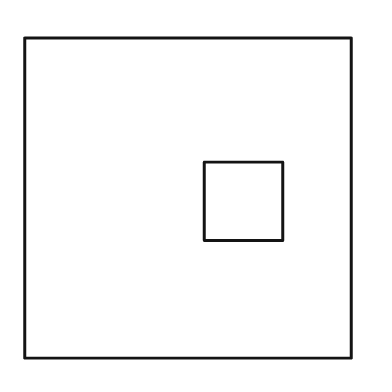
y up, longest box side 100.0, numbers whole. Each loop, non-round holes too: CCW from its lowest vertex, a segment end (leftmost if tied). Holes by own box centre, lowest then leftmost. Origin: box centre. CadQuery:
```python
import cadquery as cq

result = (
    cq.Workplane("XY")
    .moveTo(-50.0, -49.0)
    .lineTo(50.0, -49.0)
    .lineTo(50.0, 49.0)
    .lineTo(-50.0, 49.0)
    .close()
    .moveTo(5.0, -13.0)
    .lineTo(29.0, -13.0)
    .lineTo(29.0, 11.0)
    .lineTo(5.0, 11.0)
    .close()
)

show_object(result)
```